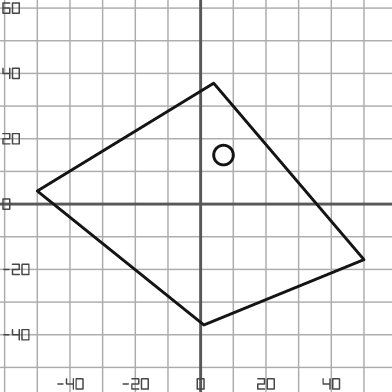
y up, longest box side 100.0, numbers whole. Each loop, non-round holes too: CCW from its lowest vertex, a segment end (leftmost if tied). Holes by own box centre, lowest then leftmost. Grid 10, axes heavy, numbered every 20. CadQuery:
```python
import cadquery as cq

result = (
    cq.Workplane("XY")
    .moveTo(1.0, -37.0)
    .lineTo(50.0, -17.0)
    .lineTo(4.0, 37.0)
    .lineTo(-50.0, 4.0)
    .close()
    .moveTo(7.0, 15.0)
    .circle(3.0)
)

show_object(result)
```